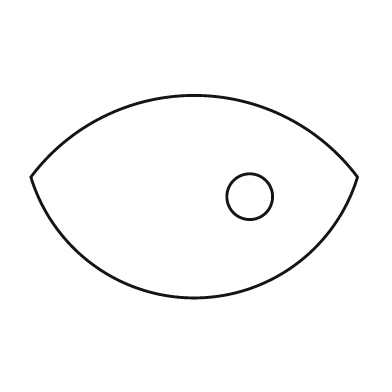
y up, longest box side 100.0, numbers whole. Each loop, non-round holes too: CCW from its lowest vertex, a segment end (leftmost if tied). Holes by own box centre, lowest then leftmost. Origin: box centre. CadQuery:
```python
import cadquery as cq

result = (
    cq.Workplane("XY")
    .moveTo(-50.0, 6.0)
    .threePointArc((0.0, -31.0), (50.0, 6.0))
    .threePointArc((0.0, 31.0), (-50.0, 6.0))
    .close()
    .moveTo(17.0, 0.0)
    .circle(7.0)
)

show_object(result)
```